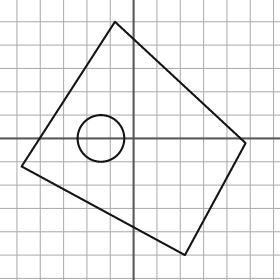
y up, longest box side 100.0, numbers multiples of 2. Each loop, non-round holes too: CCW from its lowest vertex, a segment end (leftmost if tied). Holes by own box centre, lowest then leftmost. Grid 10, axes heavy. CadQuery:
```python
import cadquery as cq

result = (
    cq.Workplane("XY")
    .moveTo(22.0, -50.0)
    .lineTo(48.0, -2.0)
    .lineTo(-8.0, 50.0)
    .lineTo(-48.0, -12.0)
    .close()
    .moveTo(-14.0, 0.0)
    .circle(10.0)
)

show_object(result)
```